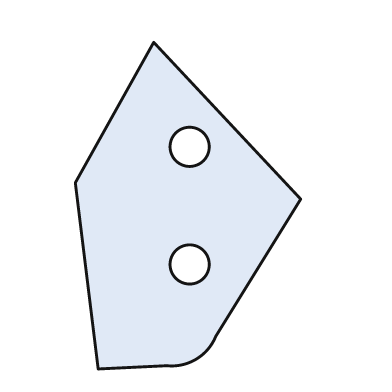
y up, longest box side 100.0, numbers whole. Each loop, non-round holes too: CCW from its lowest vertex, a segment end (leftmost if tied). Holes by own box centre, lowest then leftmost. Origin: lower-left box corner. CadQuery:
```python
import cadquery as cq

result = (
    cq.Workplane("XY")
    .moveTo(7.0, 0.0)
    .lineTo(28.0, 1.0)
    .threePointArc((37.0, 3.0), (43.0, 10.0))
    .lineTo(69.0, 52.0)
    .lineTo(24.0, 100.0)
    .lineTo(0.0, 57.0)
    .close()
    .moveTo(35.0, 32.0)
    .circle(6.0)
    .moveTo(35.0, 68.0)
    .circle(6.0)
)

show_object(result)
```